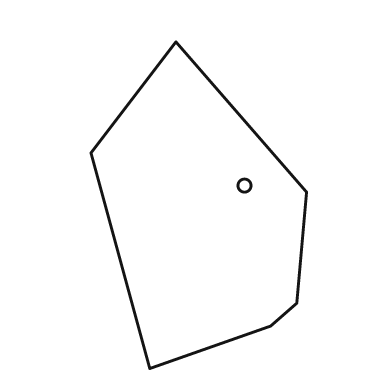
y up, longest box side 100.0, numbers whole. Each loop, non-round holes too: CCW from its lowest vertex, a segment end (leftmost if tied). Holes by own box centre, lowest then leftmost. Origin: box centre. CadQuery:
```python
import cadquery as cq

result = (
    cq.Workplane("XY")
    .moveTo(-15.0, -50.0)
    .lineTo(22.0, -37.0)
    .lineTo(30.0, -30.0)
    .lineTo(33.0, 4.0)
    .lineTo(-7.0, 50.0)
    .lineTo(-33.0, 16.0)
    .close()
    .moveTo(14.0, 6.0)
    .circle(2.0)
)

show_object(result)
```